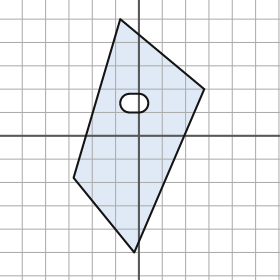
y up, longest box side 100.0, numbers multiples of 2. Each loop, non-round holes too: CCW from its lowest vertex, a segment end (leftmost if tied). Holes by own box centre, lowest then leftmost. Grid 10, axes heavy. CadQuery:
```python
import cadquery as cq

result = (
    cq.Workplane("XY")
    .moveTo(-2.0, -50.0)
    .lineTo(28.0, 20.0)
    .lineTo(-8.0, 50.0)
    .lineTo(-28.0, -18.0)
    .close()
    .moveTo(-4.0, 10.0)
    .lineTo(0.0, 10.0)
    .threePointArc((4.0, 14.0), (0.0, 18.0))
    .lineTo(-4.0, 18.0)
    .threePointArc((-8.0, 14.0), (-4.0, 10.0))
    .close()
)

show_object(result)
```